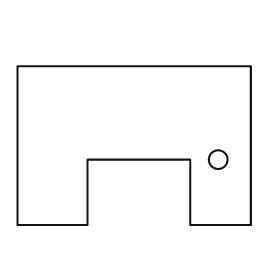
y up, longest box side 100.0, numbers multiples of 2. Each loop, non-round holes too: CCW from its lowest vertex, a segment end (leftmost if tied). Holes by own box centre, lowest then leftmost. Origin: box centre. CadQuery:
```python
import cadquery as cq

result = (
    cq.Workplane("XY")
    .moveTo(-50.0, -34.0)
    .lineTo(-20.0, -34.0)
    .lineTo(-20.0, -6.0)
    .lineTo(24.0, -6.0)
    .lineTo(24.0, -34.0)
    .lineTo(50.0, -34.0)
    .lineTo(50.0, 34.0)
    .lineTo(-50.0, 34.0)
    .close()
    .moveTo(36.0, -6.0)
    .circle(4.0)
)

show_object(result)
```